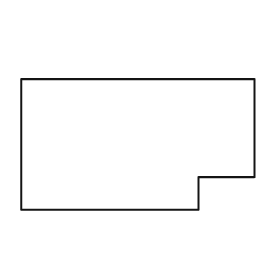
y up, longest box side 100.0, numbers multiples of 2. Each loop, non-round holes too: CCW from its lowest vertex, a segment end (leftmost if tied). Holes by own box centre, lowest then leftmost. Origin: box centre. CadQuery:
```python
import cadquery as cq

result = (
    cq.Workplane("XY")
    .moveTo(-50.0, -28.0)
    .lineTo(26.0, -28.0)
    .lineTo(26.0, -14.0)
    .lineTo(50.0, -14.0)
    .lineTo(50.0, 28.0)
    .lineTo(-50.0, 28.0)
    .close()
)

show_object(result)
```